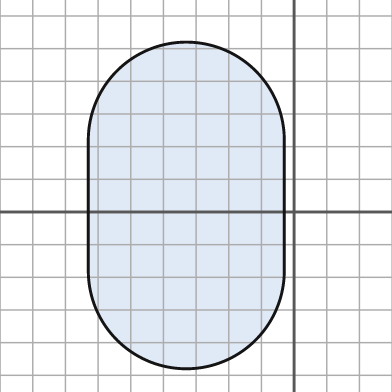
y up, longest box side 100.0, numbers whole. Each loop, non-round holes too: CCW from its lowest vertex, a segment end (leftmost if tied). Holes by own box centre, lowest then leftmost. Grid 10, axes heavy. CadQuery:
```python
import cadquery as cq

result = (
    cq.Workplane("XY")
    .moveTo(-63.0, -18.0)
    .threePointArc((-33.0, -48.0), (-3.0, -18.0))
    .lineTo(-3.0, 22.0)
    .threePointArc((-33.0, 52.0), (-63.0, 22.0))
    .close()
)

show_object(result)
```